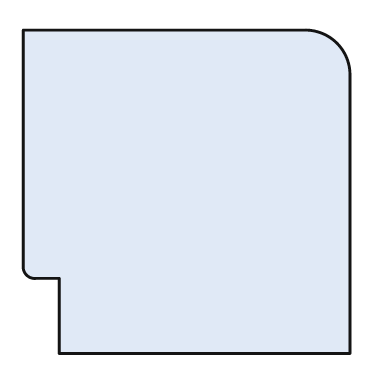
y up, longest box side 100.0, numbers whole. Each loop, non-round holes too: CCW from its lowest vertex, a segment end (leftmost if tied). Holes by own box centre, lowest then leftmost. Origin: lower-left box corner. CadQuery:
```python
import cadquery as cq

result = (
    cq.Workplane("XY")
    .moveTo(11.0, 0.0)
    .lineTo(100.0, 0.0)
    .lineTo(100.0, 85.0)
    .threePointArc((96.0, 95.0), (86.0, 99.0))
    .lineTo(0.0, 99.0)
    .lineTo(0.0, 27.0)
    .threePointArc((1.0, 24.0), (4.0, 23.0))
    .lineTo(11.0, 23.0)
    .close()
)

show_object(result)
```